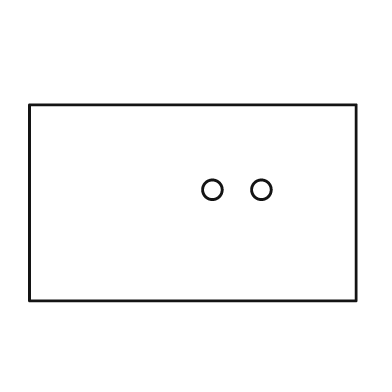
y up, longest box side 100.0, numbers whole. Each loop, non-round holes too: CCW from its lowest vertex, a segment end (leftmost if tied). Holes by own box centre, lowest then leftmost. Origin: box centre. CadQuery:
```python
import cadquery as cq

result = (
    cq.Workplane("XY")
    .moveTo(-50.0, -30.0)
    .lineTo(50.0, -30.0)
    .lineTo(50.0, 30.0)
    .lineTo(-50.0, 30.0)
    .close()
    .moveTo(6.0, 4.0)
    .circle(3.0)
    .moveTo(21.0, 4.0)
    .circle(3.0)
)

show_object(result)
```